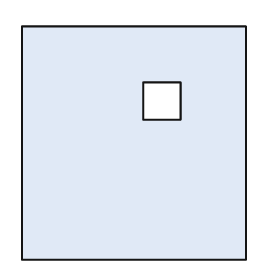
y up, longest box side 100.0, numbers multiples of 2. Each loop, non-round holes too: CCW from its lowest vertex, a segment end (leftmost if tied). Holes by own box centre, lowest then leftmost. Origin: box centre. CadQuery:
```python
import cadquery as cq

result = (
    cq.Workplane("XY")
    .moveTo(-48.0, -50.0)
    .lineTo(48.0, -50.0)
    .lineTo(48.0, 50.0)
    .lineTo(-48.0, 50.0)
    .close()
    .moveTo(4.0, 10.0)
    .lineTo(20.0, 10.0)
    .lineTo(20.0, 26.0)
    .lineTo(4.0, 26.0)
    .close()
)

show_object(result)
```